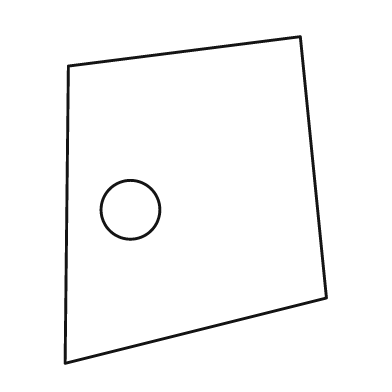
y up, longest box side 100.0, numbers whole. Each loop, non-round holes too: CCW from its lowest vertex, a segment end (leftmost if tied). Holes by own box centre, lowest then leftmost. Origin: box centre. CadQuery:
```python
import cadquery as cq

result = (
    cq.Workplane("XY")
    .moveTo(-40.0, -50.0)
    .lineTo(40.0, -30.0)
    .lineTo(32.0, 50.0)
    .lineTo(-39.0, 41.0)
    .close()
    .moveTo(-20.0, -3.0)
    .circle(9.0)
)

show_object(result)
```